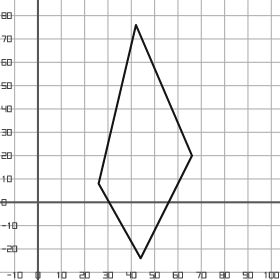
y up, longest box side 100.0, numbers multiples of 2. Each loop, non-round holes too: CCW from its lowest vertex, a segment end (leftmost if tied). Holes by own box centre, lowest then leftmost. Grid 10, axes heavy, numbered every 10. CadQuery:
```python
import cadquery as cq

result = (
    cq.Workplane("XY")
    .moveTo(44.0, -24.0)
    .lineTo(66.0, 20.0)
    .lineTo(42.0, 76.0)
    .lineTo(26.0, 8.0)
    .close()
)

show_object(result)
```